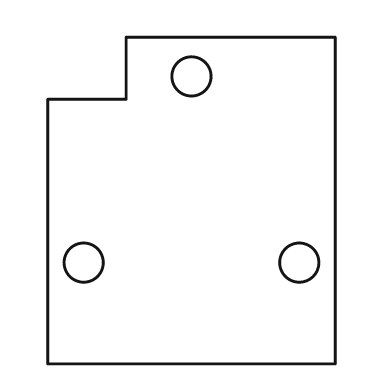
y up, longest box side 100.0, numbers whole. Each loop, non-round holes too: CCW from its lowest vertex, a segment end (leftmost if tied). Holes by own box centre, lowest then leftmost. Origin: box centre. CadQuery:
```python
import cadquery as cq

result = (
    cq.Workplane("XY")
    .moveTo(-44.0, -50.0)
    .lineTo(44.0, -50.0)
    .lineTo(44.0, 50.0)
    .lineTo(-20.0, 50.0)
    .lineTo(-20.0, 31.0)
    .lineTo(-44.0, 31.0)
    .close()
    .moveTo(-33.0, -19.0)
    .circle(6.0)
    .moveTo(33.0, -19.0)
    .circle(6.0)
    .moveTo(0.0, 38.0)
    .circle(6.0)
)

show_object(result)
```